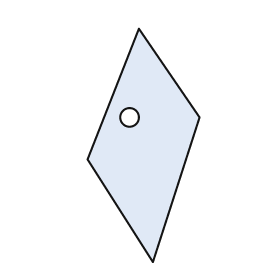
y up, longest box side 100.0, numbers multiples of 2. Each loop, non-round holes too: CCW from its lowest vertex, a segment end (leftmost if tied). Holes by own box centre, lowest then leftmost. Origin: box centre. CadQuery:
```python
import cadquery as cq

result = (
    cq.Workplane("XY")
    .moveTo(4.0, -50.0)
    .lineTo(24.0, 12.0)
    .lineTo(-2.0, 50.0)
    .lineTo(-24.0, -6.0)
    .close()
    .moveTo(-6.0, 12.0)
    .circle(4.0)
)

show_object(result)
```